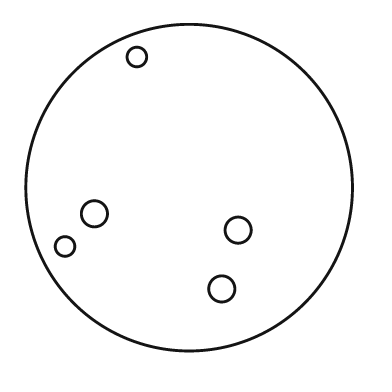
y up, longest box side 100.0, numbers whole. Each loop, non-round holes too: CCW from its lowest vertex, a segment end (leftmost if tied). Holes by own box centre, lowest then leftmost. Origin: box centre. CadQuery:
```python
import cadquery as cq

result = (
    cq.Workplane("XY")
    .moveTo(0.0, 0.0)
    .circle(50.0)
    .moveTo(10.0, -31.0)
    .circle(4.0)
    .moveTo(-38.0, -18.0)
    .circle(3.0)
    .moveTo(15.0, -13.0)
    .circle(4.0)
    .moveTo(-29.0, -8.0)
    .circle(4.0)
    .moveTo(-16.0, 40.0)
    .circle(3.0)
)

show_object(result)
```